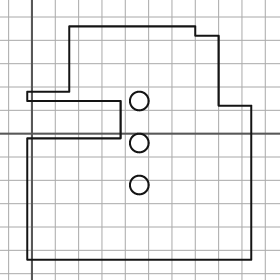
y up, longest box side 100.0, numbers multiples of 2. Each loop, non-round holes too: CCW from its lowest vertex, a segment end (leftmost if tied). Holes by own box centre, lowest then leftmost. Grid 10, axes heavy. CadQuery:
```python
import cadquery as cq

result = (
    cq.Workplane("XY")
    .moveTo(-2.0, -54.0)
    .lineTo(94.0, -54.0)
    .lineTo(94.0, 12.0)
    .lineTo(80.0, 12.0)
    .lineTo(80.0, 42.0)
    .lineTo(70.0, 42.0)
    .lineTo(70.0, 46.0)
    .lineTo(16.0, 46.0)
    .lineTo(16.0, 18.0)
    .lineTo(-2.0, 18.0)
    .lineTo(-2.0, 14.0)
    .lineTo(38.0, 14.0)
    .lineTo(38.0, -2.0)
    .lineTo(-2.0, -2.0)
    .close()
    .moveTo(46.0, -22.0)
    .circle(4.0)
    .moveTo(46.0, -4.0)
    .circle(4.0)
    .moveTo(46.0, 14.0)
    .circle(4.0)
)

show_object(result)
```